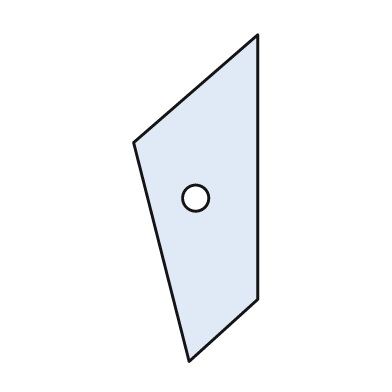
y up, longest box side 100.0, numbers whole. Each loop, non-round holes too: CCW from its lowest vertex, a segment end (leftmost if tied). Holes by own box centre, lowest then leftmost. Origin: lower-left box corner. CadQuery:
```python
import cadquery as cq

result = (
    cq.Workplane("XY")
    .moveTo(17.0, 0.0)
    .lineTo(38.0, 19.0)
    .lineTo(38.0, 100.0)
    .lineTo(0.0, 67.0)
    .close()
    .moveTo(19.0, 50.0)
    .circle(4.0)
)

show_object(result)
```